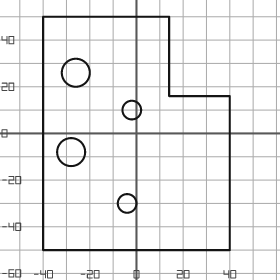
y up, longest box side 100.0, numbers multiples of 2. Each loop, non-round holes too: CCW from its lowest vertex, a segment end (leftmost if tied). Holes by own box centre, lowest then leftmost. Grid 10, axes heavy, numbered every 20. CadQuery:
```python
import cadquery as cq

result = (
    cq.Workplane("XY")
    .moveTo(-40.0, -50.0)
    .lineTo(40.0, -50.0)
    .lineTo(40.0, 16.0)
    .lineTo(14.0, 16.0)
    .lineTo(14.0, 50.0)
    .lineTo(-40.0, 50.0)
    .close()
    .moveTo(-4.0, -30.0)
    .circle(4.0)
    .moveTo(-28.0, -8.0)
    .circle(6.0)
    .moveTo(-2.0, 10.0)
    .circle(4.0)
    .moveTo(-26.0, 26.0)
    .circle(6.0)
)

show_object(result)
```